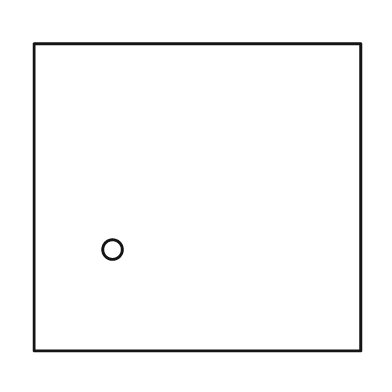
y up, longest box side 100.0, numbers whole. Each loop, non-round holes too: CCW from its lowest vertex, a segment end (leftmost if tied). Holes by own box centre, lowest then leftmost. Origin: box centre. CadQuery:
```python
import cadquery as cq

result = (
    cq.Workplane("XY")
    .moveTo(-50.0, -47.0)
    .lineTo(50.0, -47.0)
    .lineTo(50.0, 47.0)
    .lineTo(-50.0, 47.0)
    .close()
    .moveTo(-26.0, -16.0)
    .circle(3.0)
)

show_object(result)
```